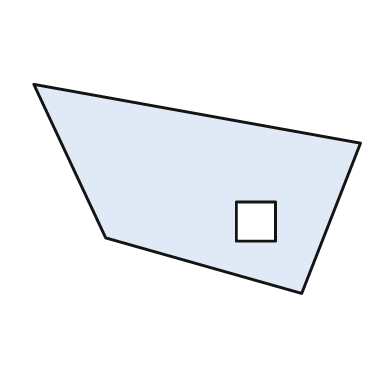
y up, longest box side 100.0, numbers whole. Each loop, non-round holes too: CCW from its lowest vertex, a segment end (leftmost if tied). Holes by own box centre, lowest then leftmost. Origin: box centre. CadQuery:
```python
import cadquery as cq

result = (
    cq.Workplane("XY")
    .moveTo(32.0, -32.0)
    .lineTo(50.0, 14.0)
    .lineTo(-50.0, 32.0)
    .lineTo(-28.0, -15.0)
    .close()
    .moveTo(12.0, -16.0)
    .lineTo(24.0, -16.0)
    .lineTo(24.0, -4.0)
    .lineTo(12.0, -4.0)
    .close()
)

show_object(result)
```